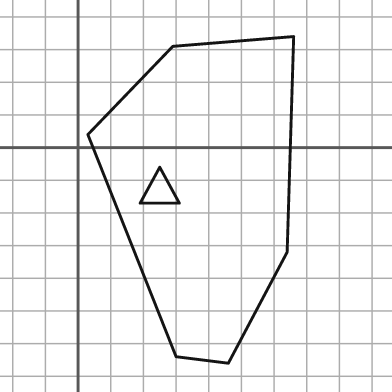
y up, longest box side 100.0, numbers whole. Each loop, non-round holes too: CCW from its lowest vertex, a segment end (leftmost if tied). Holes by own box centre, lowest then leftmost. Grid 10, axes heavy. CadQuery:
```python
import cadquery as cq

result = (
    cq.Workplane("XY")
    .moveTo(46.0, -66.0)
    .lineTo(64.0, -32.0)
    .lineTo(66.0, 34.0)
    .lineTo(29.0, 31.0)
    .lineTo(3.0, 4.0)
    .lineTo(30.0, -64.0)
    .close()
    .moveTo(19.0, -17.0)
    .lineTo(31.0, -17.0)
    .lineTo(25.0, -6.0)
    .close()
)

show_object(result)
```